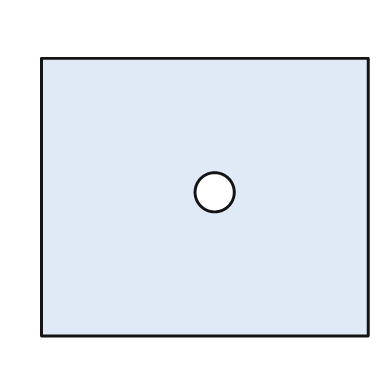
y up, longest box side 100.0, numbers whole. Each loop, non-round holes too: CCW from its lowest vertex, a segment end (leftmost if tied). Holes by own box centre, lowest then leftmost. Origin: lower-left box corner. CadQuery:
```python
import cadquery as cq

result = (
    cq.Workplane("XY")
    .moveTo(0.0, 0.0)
    .lineTo(100.0, 0.0)
    .lineTo(100.0, 85.0)
    .lineTo(0.0, 85.0)
    .close()
    .moveTo(53.0, 44.0)
    .circle(6.0)
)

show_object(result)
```